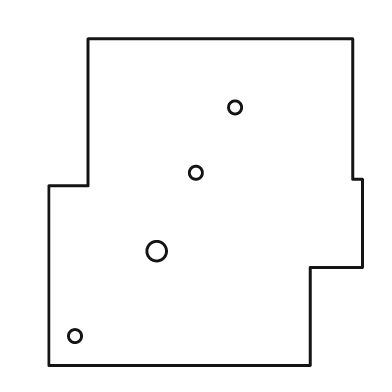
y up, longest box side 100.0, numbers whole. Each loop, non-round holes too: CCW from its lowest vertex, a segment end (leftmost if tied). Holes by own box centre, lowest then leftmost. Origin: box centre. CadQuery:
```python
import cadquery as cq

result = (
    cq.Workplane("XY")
    .moveTo(-48.0, -50.0)
    .lineTo(32.0, -50.0)
    .lineTo(32.0, -20.0)
    .lineTo(48.0, -20.0)
    .lineTo(48.0, 7.0)
    .lineTo(45.0, 7.0)
    .lineTo(45.0, 50.0)
    .lineTo(-36.0, 50.0)
    .lineTo(-36.0, 5.0)
    .lineTo(-48.0, 5.0)
    .close()
    .moveTo(-40.0, -41.0)
    .circle(2.0)
    .moveTo(-15.0, -15.0)
    .circle(3.0)
    .moveTo(-3.0, 9.0)
    .circle(2.0)
    .moveTo(9.0, 29.0)
    .circle(2.0)
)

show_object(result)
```